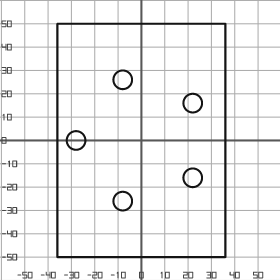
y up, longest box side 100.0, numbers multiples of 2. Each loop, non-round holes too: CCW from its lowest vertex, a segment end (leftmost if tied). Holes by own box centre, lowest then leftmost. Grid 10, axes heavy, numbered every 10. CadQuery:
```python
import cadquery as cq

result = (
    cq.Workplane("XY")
    .moveTo(-36.0, -50.0)
    .lineTo(36.0, -50.0)
    .lineTo(36.0, 50.0)
    .lineTo(-36.0, 50.0)
    .close()
    .moveTo(-8.0, -26.0)
    .circle(4.0)
    .moveTo(22.0, -16.0)
    .circle(4.0)
    .moveTo(-28.0, 0.0)
    .circle(4.0)
    .moveTo(22.0, 16.0)
    .circle(4.0)
    .moveTo(-8.0, 26.0)
    .circle(4.0)
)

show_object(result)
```